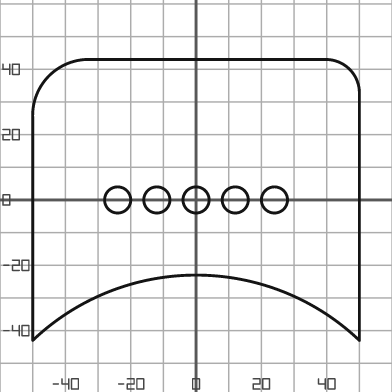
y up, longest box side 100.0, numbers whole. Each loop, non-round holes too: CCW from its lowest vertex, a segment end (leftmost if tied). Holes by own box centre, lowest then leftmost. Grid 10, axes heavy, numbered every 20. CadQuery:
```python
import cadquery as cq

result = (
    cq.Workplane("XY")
    .moveTo(-50.0, -43.0)
    .threePointArc((0.0, -23.0), (50.0, -43.0))
    .lineTo(50.0, 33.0)
    .threePointArc((47.0, 40.0), (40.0, 43.0))
    .lineTo(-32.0, 43.0)
    .threePointArc((-45.0, 38.0), (-50.0, 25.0))
    .close()
    .moveTo(-24.0, 0.0)
    .circle(4.0)
    .moveTo(-12.0, 0.0)
    .circle(4.0)
    .moveTo(0.0, 0.0)
    .circle(4.0)
    .moveTo(12.0, 0.0)
    .circle(4.0)
    .moveTo(24.0, 0.0)
    .circle(4.0)
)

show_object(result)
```